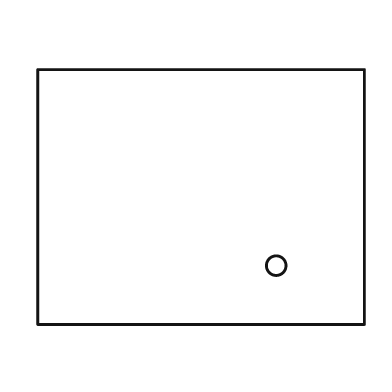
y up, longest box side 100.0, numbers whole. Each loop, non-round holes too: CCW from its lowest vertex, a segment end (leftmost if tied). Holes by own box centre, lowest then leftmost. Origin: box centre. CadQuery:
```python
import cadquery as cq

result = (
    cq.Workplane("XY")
    .moveTo(-50.0, -39.0)
    .lineTo(50.0, -39.0)
    .lineTo(50.0, 39.0)
    .lineTo(-50.0, 39.0)
    .close()
    .moveTo(23.0, -21.0)
    .circle(3.0)
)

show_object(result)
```